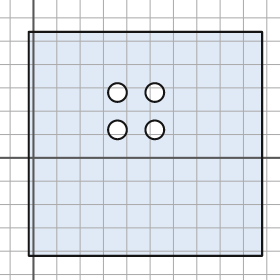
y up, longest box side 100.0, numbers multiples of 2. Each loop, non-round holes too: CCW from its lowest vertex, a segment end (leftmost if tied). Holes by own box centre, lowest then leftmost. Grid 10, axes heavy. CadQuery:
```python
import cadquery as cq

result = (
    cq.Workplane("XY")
    .moveTo(-2.0, -42.0)
    .lineTo(98.0, -42.0)
    .lineTo(98.0, 54.0)
    .lineTo(-2.0, 54.0)
    .close()
    .moveTo(36.0, 12.0)
    .circle(4.0)
    .moveTo(52.0, 12.0)
    .circle(4.0)
    .moveTo(36.0, 28.0)
    .circle(4.0)
    .moveTo(52.0, 28.0)
    .circle(4.0)
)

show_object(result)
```